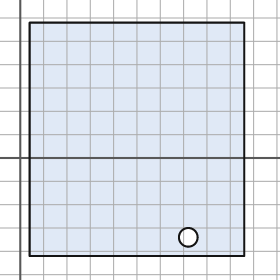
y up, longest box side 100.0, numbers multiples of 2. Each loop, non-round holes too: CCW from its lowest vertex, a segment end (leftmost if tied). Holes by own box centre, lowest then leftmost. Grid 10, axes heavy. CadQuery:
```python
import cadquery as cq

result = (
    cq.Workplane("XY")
    .moveTo(4.0, -42.0)
    .lineTo(96.0, -42.0)
    .lineTo(96.0, 58.0)
    .lineTo(4.0, 58.0)
    .close()
    .moveTo(72.0, -34.0)
    .circle(4.0)
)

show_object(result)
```